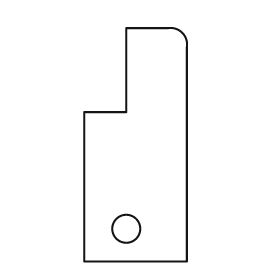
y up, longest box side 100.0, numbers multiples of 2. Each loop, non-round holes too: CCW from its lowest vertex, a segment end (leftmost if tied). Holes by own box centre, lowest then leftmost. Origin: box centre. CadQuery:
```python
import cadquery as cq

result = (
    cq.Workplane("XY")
    .moveTo(-22.0, -50.0)
    .lineTo(22.0, -50.0)
    .lineTo(22.0, 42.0)
    .threePointArc((20.0, 48.0), (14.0, 50.0))
    .lineTo(-4.0, 50.0)
    .lineTo(-4.0, 14.0)
    .lineTo(-22.0, 14.0)
    .close()
    .moveTo(-4.0, -36.0)
    .circle(6.0)
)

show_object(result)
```